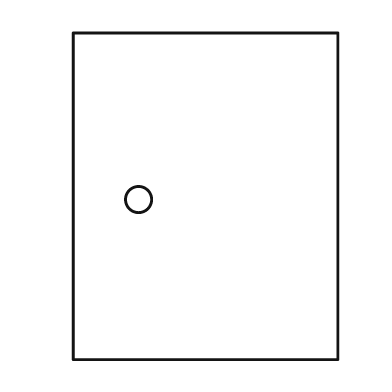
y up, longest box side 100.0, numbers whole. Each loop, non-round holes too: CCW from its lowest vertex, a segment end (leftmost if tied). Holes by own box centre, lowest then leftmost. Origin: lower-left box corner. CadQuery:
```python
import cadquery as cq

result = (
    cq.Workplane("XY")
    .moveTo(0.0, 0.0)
    .lineTo(81.0, 0.0)
    .lineTo(81.0, 100.0)
    .lineTo(0.0, 100.0)
    .close()
    .moveTo(20.0, 49.0)
    .circle(4.0)
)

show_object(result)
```